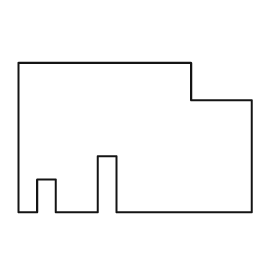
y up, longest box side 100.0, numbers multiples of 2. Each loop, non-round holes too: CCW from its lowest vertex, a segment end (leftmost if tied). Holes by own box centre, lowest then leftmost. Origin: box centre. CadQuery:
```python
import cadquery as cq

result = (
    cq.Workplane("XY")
    .moveTo(-50.0, -32.0)
    .lineTo(-42.0, -32.0)
    .lineTo(-42.0, -18.0)
    .lineTo(-34.0, -18.0)
    .lineTo(-34.0, -32.0)
    .lineTo(-16.0, -32.0)
    .lineTo(-16.0, -8.0)
    .lineTo(-8.0, -8.0)
    .lineTo(-8.0, -32.0)
    .lineTo(50.0, -32.0)
    .lineTo(50.0, 16.0)
    .lineTo(24.0, 16.0)
    .lineTo(24.0, 32.0)
    .lineTo(-50.0, 32.0)
    .close()
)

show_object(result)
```